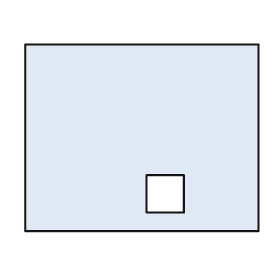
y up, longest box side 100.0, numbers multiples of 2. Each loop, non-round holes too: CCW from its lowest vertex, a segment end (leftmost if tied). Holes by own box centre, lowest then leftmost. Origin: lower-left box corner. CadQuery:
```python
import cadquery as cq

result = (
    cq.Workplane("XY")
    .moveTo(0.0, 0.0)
    .lineTo(100.0, 0.0)
    .lineTo(100.0, 80.0)
    .lineTo(0.0, 80.0)
    .close()
    .moveTo(52.0, 8.0)
    .lineTo(68.0, 8.0)
    .lineTo(68.0, 24.0)
    .lineTo(52.0, 24.0)
    .close()
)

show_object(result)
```